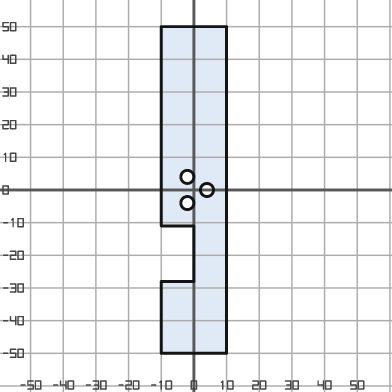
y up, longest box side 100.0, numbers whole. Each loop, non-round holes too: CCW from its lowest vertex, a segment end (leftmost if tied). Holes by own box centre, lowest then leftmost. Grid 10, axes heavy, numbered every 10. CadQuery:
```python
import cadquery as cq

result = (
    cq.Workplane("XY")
    .moveTo(-10.0, -50.0)
    .lineTo(10.0, -50.0)
    .lineTo(10.0, 50.0)
    .lineTo(-10.0, 50.0)
    .lineTo(-10.0, -11.0)
    .lineTo(0.0, -11.0)
    .lineTo(0.0, -28.0)
    .lineTo(-10.0, -28.0)
    .close()
    .moveTo(-2.0, -4.0)
    .circle(2.0)
    .moveTo(4.0, 0.0)
    .circle(2.0)
    .moveTo(-2.0, 4.0)
    .circle(2.0)
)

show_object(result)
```